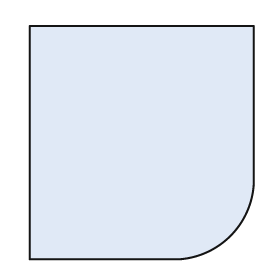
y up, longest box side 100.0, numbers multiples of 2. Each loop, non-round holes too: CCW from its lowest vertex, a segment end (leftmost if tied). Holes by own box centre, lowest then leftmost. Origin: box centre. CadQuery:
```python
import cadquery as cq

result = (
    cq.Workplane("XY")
    .moveTo(-48.0, -50.0)
    .lineTo(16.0, -50.0)
    .threePointArc((38.0, -40.0), (48.0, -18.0))
    .lineTo(48.0, 50.0)
    .lineTo(-48.0, 50.0)
    .close()
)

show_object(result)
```